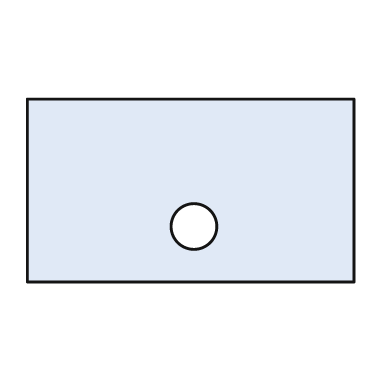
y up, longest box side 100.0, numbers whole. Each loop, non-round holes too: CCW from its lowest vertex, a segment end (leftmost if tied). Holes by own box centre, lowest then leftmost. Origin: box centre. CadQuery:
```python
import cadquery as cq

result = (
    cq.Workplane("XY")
    .moveTo(-50.0, -28.0)
    .lineTo(50.0, -28.0)
    .lineTo(50.0, 28.0)
    .lineTo(-50.0, 28.0)
    .close()
    .moveTo(1.0, -11.0)
    .circle(7.0)
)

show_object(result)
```